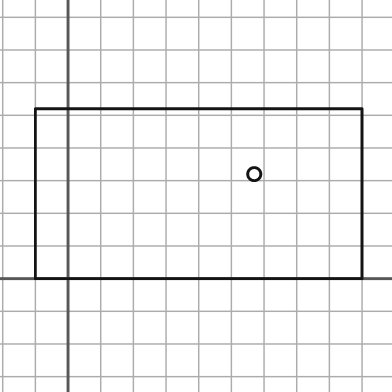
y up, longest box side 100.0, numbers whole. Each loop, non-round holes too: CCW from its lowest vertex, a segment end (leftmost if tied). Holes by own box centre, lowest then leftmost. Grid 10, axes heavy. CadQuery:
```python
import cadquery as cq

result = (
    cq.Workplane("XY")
    .moveTo(-10.0, 0.0)
    .lineTo(90.0, 0.0)
    .lineTo(90.0, 52.0)
    .lineTo(-10.0, 52.0)
    .close()
    .moveTo(57.0, 32.0)
    .circle(2.0)
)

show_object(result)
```